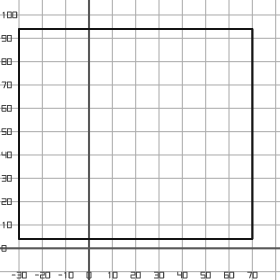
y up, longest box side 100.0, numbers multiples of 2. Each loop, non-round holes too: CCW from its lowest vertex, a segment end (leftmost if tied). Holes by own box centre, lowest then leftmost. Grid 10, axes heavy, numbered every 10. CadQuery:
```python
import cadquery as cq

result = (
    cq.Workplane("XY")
    .moveTo(-30.0, 4.0)
    .lineTo(70.0, 4.0)
    .lineTo(70.0, 94.0)
    .lineTo(-30.0, 94.0)
    .close()
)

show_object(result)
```